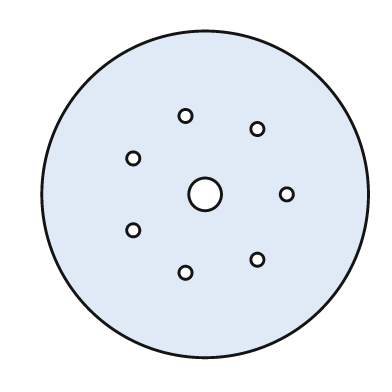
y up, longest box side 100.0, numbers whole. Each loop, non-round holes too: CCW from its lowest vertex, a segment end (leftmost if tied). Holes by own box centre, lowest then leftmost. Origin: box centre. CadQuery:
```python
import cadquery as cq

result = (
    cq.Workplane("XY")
    .moveTo(0.0, 0.0)
    .circle(50.0)
    .moveTo(-6.0, -24.0)
    .circle(2.0)
    .moveTo(16.0, -20.0)
    .circle(2.0)
    .moveTo(-22.0, -11.0)
    .circle(2.0)
    .moveTo(0.0, 0.0)
    .circle(5.0)
    .moveTo(25.0, 0.0)
    .circle(2.0)
    .moveTo(-22.0, 11.0)
    .circle(2.0)
    .moveTo(16.0, 20.0)
    .circle(2.0)
    .moveTo(-6.0, 24.0)
    .circle(2.0)
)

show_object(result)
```